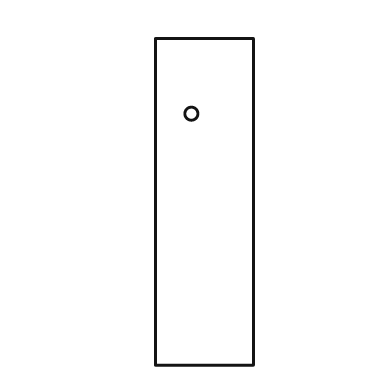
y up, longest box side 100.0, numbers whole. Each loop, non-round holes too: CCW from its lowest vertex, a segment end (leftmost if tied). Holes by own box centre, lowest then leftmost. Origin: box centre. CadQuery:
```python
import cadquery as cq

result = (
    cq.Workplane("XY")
    .moveTo(-15.0, -50.0)
    .lineTo(15.0, -50.0)
    .lineTo(15.0, 50.0)
    .lineTo(-15.0, 50.0)
    .close()
    .moveTo(-4.0, 27.0)
    .circle(2.0)
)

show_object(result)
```